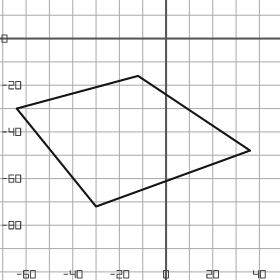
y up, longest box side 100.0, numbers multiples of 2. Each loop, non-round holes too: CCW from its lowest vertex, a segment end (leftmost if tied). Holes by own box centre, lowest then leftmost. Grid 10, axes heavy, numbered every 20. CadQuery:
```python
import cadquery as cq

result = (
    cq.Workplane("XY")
    .moveTo(-30.0, -72.0)
    .lineTo(36.0, -48.0)
    .lineTo(-12.0, -16.0)
    .lineTo(-64.0, -30.0)
    .close()
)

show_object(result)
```